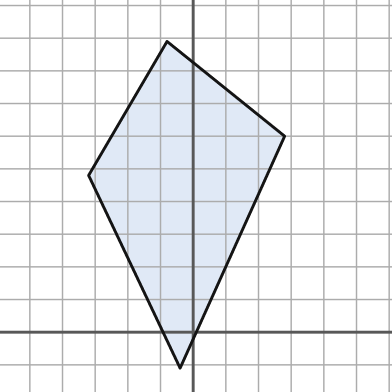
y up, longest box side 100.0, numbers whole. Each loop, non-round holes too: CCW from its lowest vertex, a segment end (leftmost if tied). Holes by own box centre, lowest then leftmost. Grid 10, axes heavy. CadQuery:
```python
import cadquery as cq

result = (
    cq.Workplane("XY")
    .moveTo(-4.0, -11.0)
    .lineTo(28.0, 60.0)
    .lineTo(-8.0, 89.0)
    .lineTo(-32.0, 48.0)
    .close()
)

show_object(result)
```